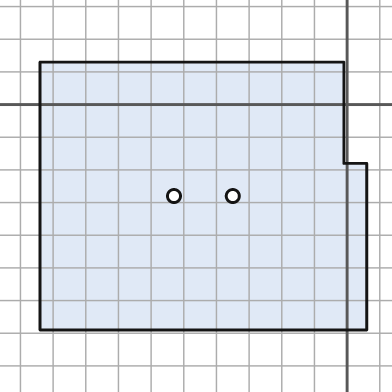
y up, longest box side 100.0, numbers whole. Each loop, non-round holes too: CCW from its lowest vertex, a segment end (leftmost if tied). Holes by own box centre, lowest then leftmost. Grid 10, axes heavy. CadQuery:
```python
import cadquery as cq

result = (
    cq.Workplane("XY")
    .moveTo(-94.0, -69.0)
    .lineTo(6.0, -69.0)
    .lineTo(6.0, -18.0)
    .lineTo(-1.0, -18.0)
    .lineTo(-1.0, 13.0)
    .lineTo(-94.0, 13.0)
    .close()
    .moveTo(-53.0, -28.0)
    .circle(2.0)
    .moveTo(-35.0, -28.0)
    .circle(2.0)
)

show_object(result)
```